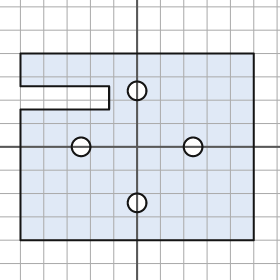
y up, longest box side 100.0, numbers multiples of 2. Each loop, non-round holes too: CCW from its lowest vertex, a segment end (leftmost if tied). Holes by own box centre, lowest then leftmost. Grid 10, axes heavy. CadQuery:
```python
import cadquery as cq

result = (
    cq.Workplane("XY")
    .moveTo(-50.0, -40.0)
    .lineTo(50.0, -40.0)
    .lineTo(50.0, 40.0)
    .lineTo(-50.0, 40.0)
    .lineTo(-50.0, 26.0)
    .lineTo(-12.0, 26.0)
    .lineTo(-12.0, 16.0)
    .lineTo(-50.0, 16.0)
    .close()
    .moveTo(0.0, -24.0)
    .circle(4.0)
    .moveTo(-24.0, 0.0)
    .circle(4.0)
    .moveTo(24.0, 0.0)
    .circle(4.0)
    .moveTo(0.0, 24.0)
    .circle(4.0)
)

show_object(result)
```